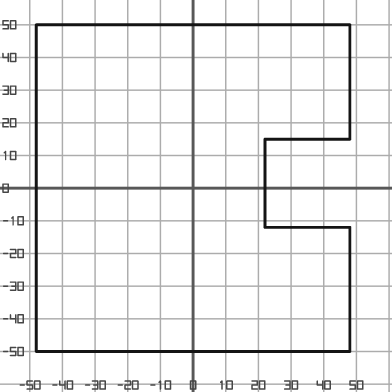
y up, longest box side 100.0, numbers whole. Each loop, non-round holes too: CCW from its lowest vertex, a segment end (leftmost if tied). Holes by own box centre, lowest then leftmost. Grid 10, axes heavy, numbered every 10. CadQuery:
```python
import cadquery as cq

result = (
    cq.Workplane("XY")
    .moveTo(-48.0, -50.0)
    .lineTo(48.0, -50.0)
    .lineTo(48.0, -12.0)
    .lineTo(22.0, -12.0)
    .lineTo(22.0, 15.0)
    .lineTo(48.0, 15.0)
    .lineTo(48.0, 50.0)
    .lineTo(-48.0, 50.0)
    .close()
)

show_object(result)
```